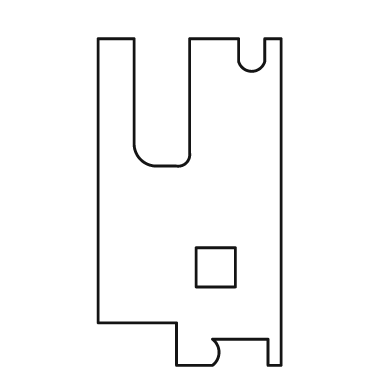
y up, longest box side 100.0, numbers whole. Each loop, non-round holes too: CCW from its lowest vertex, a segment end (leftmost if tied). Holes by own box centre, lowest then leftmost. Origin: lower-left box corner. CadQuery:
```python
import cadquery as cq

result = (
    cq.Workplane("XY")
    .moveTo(24.0, 0.0)
    .lineTo(35.0, 0.0)
    .threePointArc((37.0, 4.0), (35.0, 8.0))
    .lineTo(52.0, 8.0)
    .lineTo(52.0, 0.0)
    .lineTo(56.0, 0.0)
    .lineTo(56.0, 100.0)
    .lineTo(51.0, 100.0)
    .lineTo(51.0, 93.0)
    .threePointArc((47.0, 90.0), (43.0, 93.0))
    .lineTo(43.0, 100.0)
    .lineTo(28.0, 100.0)
    .lineTo(28.0, 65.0)
    .threePointArc((27.0, 62.0), (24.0, 61.0))
    .lineTo(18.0, 61.0)
    .threePointArc((13.0, 63.0), (11.0, 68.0))
    .lineTo(11.0, 100.0)
    .lineTo(0.0, 100.0)
    .lineTo(0.0, 13.0)
    .lineTo(24.0, 13.0)
    .close()
    .moveTo(30.0, 24.0)
    .lineTo(42.0, 24.0)
    .lineTo(42.0, 36.0)
    .lineTo(30.0, 36.0)
    .close()
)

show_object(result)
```